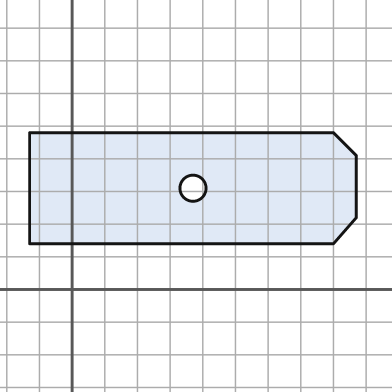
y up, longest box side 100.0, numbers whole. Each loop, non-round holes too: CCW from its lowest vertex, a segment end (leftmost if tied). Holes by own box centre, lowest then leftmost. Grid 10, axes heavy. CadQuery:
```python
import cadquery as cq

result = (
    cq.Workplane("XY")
    .moveTo(-13.0, 14.0)
    .lineTo(80.0, 14.0)
    .lineTo(87.0, 22.0)
    .lineTo(87.0, 41.0)
    .lineTo(80.0, 48.0)
    .lineTo(-13.0, 48.0)
    .close()
    .moveTo(37.0, 31.0)
    .circle(4.0)
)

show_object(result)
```